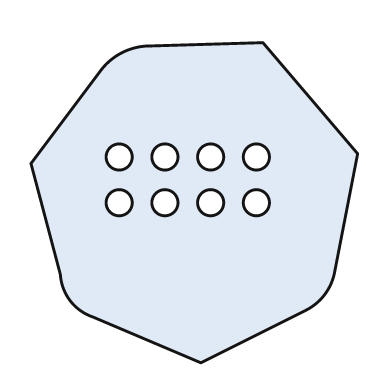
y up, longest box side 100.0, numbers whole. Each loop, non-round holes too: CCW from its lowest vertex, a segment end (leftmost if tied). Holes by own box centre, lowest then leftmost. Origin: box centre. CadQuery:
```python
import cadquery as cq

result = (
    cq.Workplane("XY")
    .moveTo(2.0, -49.0)
    .lineTo(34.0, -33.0)
    .threePointArc((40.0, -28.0), (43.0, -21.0))
    .lineTo(50.0, 15.0)
    .lineTo(21.0, 49.0)
    .lineTo(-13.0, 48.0)
    .threePointArc((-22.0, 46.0), (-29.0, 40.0))
    .lineTo(-50.0, 12.0)
    .lineTo(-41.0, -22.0)
    .threePointArc((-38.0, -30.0), (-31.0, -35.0))
    .close()
    .moveTo(-23.0, 0.0)
    .circle(4.0)
    .moveTo(-9.0, 0.0)
    .circle(4.0)
    .moveTo(5.0, 0.0)
    .circle(4.0)
    .moveTo(19.0, 0.0)
    .circle(4.0)
    .moveTo(-23.0, 14.0)
    .circle(4.0)
    .moveTo(-9.0, 14.0)
    .circle(4.0)
    .moveTo(5.0, 14.0)
    .circle(4.0)
    .moveTo(19.0, 14.0)
    .circle(4.0)
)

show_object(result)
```